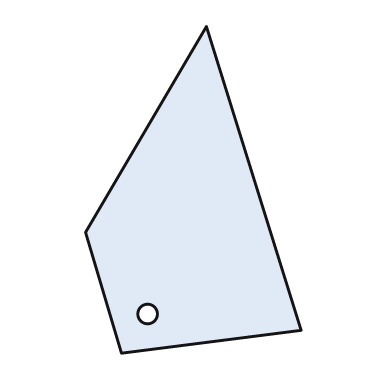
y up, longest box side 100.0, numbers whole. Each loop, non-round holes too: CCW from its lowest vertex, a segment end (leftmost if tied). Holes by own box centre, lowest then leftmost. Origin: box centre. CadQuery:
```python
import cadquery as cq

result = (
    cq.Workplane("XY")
    .moveTo(-22.0, -50.0)
    .lineTo(33.0, -43.0)
    .lineTo(4.0, 50.0)
    .lineTo(-33.0, -13.0)
    .close()
    .moveTo(-14.0, -38.0)
    .circle(3.0)
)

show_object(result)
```